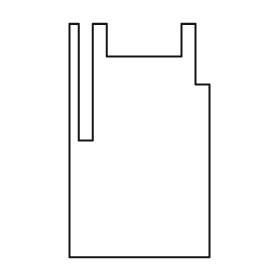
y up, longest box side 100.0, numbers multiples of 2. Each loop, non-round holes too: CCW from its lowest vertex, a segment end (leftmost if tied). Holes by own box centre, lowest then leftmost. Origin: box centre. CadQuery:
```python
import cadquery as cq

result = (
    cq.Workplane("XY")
    .moveTo(-30.0, -50.0)
    .lineTo(30.0, -50.0)
    .lineTo(30.0, 24.0)
    .lineTo(24.0, 24.0)
    .lineTo(24.0, 50.0)
    .lineTo(18.0, 50.0)
    .lineTo(18.0, 36.0)
    .lineTo(-14.0, 36.0)
    .lineTo(-14.0, 50.0)
    .lineTo(-20.0, 50.0)
    .lineTo(-20.0, 0.0)
    .lineTo(-26.0, 0.0)
    .lineTo(-26.0, 50.0)
    .lineTo(-30.0, 50.0)
    .close()
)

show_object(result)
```